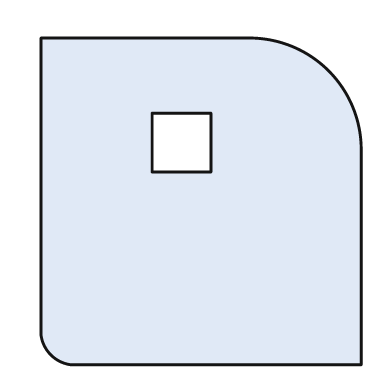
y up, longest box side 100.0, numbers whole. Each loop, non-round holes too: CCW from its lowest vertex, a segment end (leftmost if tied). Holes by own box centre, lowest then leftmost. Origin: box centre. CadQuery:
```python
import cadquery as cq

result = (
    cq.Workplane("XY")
    .moveTo(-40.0, -50.0)
    .lineTo(49.0, -50.0)
    .lineTo(49.0, 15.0)
    .threePointArc((39.0, 40.0), (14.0, 50.0))
    .lineTo(-49.0, 50.0)
    .lineTo(-49.0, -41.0)
    .threePointArc((-46.0, -47.0), (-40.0, -50.0))
    .close()
    .moveTo(-15.0, 9.0)
    .lineTo(3.0, 9.0)
    .lineTo(3.0, 27.0)
    .lineTo(-15.0, 27.0)
    .close()
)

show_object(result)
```